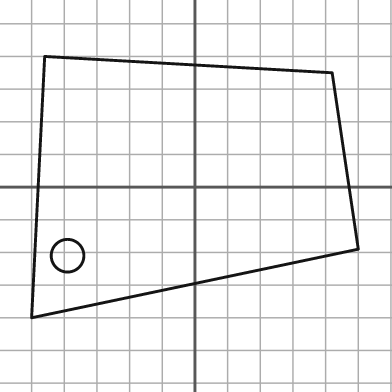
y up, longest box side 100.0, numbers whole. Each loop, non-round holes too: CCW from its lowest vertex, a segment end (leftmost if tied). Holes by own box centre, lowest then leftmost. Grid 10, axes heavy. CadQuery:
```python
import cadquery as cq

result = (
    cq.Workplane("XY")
    .moveTo(-50.0, -40.0)
    .lineTo(50.0, -19.0)
    .lineTo(42.0, 35.0)
    .lineTo(-46.0, 40.0)
    .close()
    .moveTo(-39.0, -21.0)
    .circle(5.0)
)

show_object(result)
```